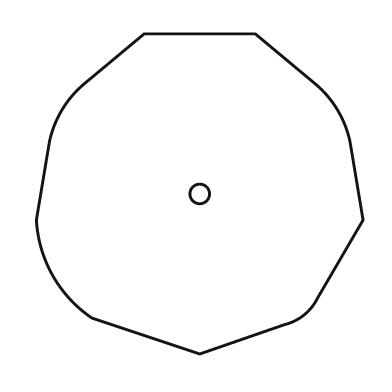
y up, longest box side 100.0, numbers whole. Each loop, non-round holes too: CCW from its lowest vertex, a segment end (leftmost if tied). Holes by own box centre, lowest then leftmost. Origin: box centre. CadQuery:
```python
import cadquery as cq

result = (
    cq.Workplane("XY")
    .moveTo(0.0, -49.0)
    .lineTo(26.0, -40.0)
    .threePointArc((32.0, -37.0), (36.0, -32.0))
    .lineTo(50.0, -8.0)
    .lineTo(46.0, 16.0)
    .threePointArc((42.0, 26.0), (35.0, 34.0))
    .lineTo(17.0, 49.0)
    .lineTo(-17.0, 49.0)
    .lineTo(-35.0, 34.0)
    .threePointArc((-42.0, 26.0), (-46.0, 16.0))
    .lineTo(-50.0, -8.0)
    .threePointArc((-45.0, -25.0), (-33.0, -38.0))
    .close()
    .moveTo(0.0, 0.0)
    .circle(3.0)
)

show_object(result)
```